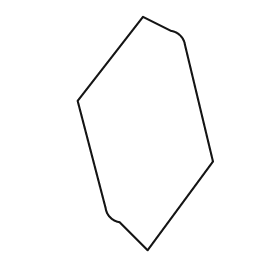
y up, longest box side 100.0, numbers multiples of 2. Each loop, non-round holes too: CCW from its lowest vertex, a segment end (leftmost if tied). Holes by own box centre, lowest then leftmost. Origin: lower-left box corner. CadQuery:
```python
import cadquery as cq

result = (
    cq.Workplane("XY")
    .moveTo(30.0, 0.0)
    .lineTo(58.0, 38.0)
    .lineTo(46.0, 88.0)
    .threePointArc((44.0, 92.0), (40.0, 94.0))
    .lineTo(28.0, 100.0)
    .lineTo(0.0, 64.0)
    .lineTo(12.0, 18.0)
    .threePointArc((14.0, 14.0), (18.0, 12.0))
    .close()
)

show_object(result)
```